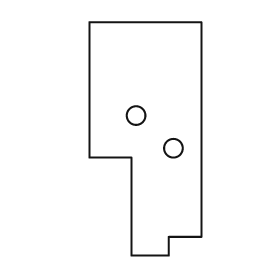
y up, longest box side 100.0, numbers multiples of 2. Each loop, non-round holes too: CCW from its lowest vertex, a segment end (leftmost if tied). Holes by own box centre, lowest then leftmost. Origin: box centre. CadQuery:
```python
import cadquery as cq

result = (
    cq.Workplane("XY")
    .moveTo(-6.0, -50.0)
    .lineTo(10.0, -50.0)
    .lineTo(10.0, -42.0)
    .lineTo(24.0, -42.0)
    .lineTo(24.0, 50.0)
    .lineTo(-24.0, 50.0)
    .lineTo(-24.0, -8.0)
    .lineTo(-6.0, -8.0)
    .close()
    .moveTo(12.0, -4.0)
    .circle(4.0)
    .moveTo(-4.0, 10.0)
    .circle(4.0)
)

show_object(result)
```